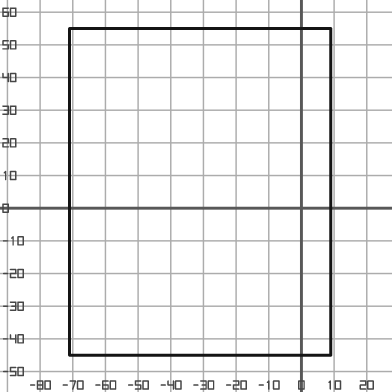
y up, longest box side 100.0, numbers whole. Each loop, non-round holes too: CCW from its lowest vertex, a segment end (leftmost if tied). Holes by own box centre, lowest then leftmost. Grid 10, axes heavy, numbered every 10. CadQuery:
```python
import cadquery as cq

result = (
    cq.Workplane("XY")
    .moveTo(-71.0, -45.0)
    .lineTo(9.0, -45.0)
    .lineTo(9.0, 55.0)
    .lineTo(-71.0, 55.0)
    .close()
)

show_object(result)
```